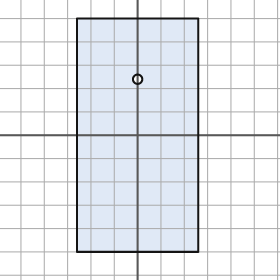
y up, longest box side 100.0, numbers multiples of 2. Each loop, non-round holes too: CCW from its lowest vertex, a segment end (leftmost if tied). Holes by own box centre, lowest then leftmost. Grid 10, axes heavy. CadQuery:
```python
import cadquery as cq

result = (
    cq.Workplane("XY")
    .moveTo(-26.0, -50.0)
    .lineTo(26.0, -50.0)
    .lineTo(26.0, 50.0)
    .lineTo(-26.0, 50.0)
    .close()
    .moveTo(0.0, 24.0)
    .circle(2.0)
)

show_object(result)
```